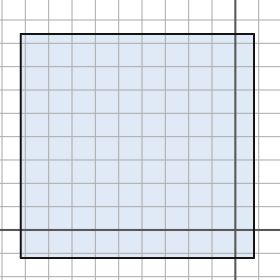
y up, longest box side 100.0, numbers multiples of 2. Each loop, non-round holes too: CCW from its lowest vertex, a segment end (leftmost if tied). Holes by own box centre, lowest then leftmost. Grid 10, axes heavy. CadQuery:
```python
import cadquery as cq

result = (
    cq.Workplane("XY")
    .moveTo(-92.0, -12.0)
    .lineTo(8.0, -12.0)
    .lineTo(8.0, 84.0)
    .lineTo(-92.0, 84.0)
    .close()
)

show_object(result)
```